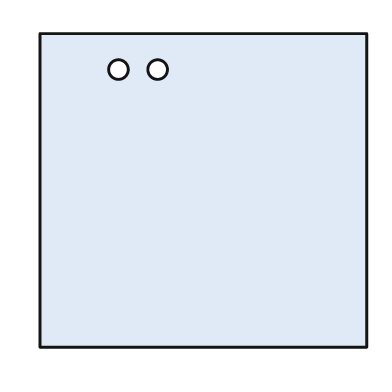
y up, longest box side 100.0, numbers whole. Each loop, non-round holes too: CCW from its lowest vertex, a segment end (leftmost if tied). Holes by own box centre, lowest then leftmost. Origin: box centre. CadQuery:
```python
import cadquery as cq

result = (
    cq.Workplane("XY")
    .moveTo(-50.0, -48.0)
    .lineTo(50.0, -48.0)
    .lineTo(50.0, 48.0)
    .lineTo(-50.0, 48.0)
    .close()
    .moveTo(-26.0, 37.0)
    .circle(3.0)
    .moveTo(-14.0, 37.0)
    .circle(3.0)
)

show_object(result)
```